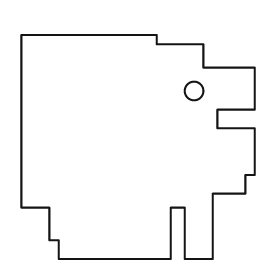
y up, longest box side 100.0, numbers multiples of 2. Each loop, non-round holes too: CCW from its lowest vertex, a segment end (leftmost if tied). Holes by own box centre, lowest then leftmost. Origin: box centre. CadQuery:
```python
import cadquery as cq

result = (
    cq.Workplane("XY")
    .moveTo(-34.0, -48.0)
    .lineTo(14.0, -48.0)
    .lineTo(14.0, -26.0)
    .lineTo(20.0, -26.0)
    .lineTo(20.0, -48.0)
    .lineTo(32.0, -48.0)
    .lineTo(32.0, -20.0)
    .lineTo(46.0, -20.0)
    .lineTo(46.0, -12.0)
    .lineTo(50.0, -12.0)
    .lineTo(50.0, 8.0)
    .lineTo(34.0, 8.0)
    .lineTo(34.0, 16.0)
    .lineTo(50.0, 16.0)
    .lineTo(50.0, 34.0)
    .lineTo(28.0, 34.0)
    .lineTo(28.0, 44.0)
    .lineTo(8.0, 44.0)
    .lineTo(8.0, 48.0)
    .lineTo(-50.0, 48.0)
    .lineTo(-50.0, -26.0)
    .lineTo(-38.0, -26.0)
    .lineTo(-38.0, -40.0)
    .lineTo(-34.0, -40.0)
    .close()
    .moveTo(24.0, 24.0)
    .circle(4.0)
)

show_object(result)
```